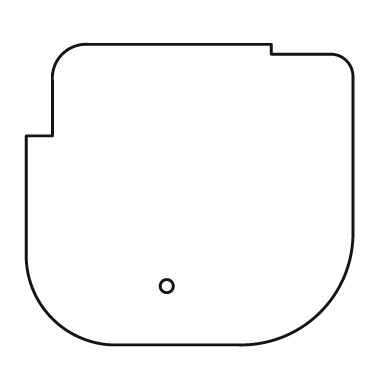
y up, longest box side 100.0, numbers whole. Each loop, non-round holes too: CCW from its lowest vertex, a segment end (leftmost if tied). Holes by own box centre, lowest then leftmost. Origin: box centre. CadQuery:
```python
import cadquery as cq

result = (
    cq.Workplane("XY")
    .moveTo(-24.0, -46.0)
    .lineTo(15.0, -46.0)
    .threePointArc((40.0, -36.0), (50.0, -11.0))
    .lineTo(50.0, 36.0)
    .threePointArc((48.0, 41.0), (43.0, 43.0))
    .lineTo(25.0, 43.0)
    .lineTo(25.0, 46.0)
    .lineTo(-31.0, 46.0)
    .threePointArc((-39.0, 43.0), (-42.0, 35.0))
    .lineTo(-42.0, 18.0)
    .lineTo(-50.0, 18.0)
    .lineTo(-50.0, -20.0)
    .threePointArc((-42.0, -38.0), (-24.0, -46.0))
    .close()
    .moveTo(-7.0, -28.0)
    .circle(2.0)
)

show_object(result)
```